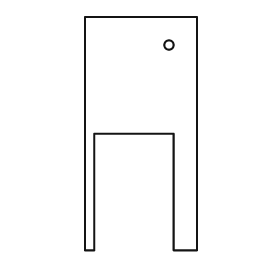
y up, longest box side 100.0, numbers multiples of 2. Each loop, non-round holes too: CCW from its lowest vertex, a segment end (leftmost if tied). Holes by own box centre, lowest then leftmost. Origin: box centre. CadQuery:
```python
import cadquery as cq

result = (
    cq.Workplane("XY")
    .moveTo(-24.0, -50.0)
    .lineTo(-20.0, -50.0)
    .lineTo(-20.0, 0.0)
    .lineTo(14.0, 0.0)
    .lineTo(14.0, -50.0)
    .lineTo(24.0, -50.0)
    .lineTo(24.0, 50.0)
    .lineTo(-24.0, 50.0)
    .close()
    .moveTo(12.0, 38.0)
    .circle(2.0)
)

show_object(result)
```